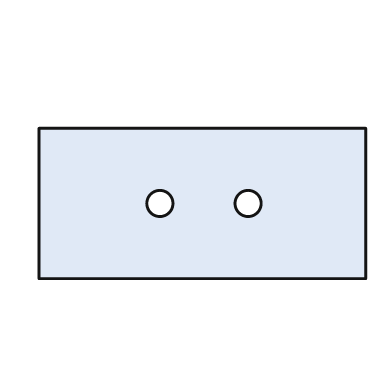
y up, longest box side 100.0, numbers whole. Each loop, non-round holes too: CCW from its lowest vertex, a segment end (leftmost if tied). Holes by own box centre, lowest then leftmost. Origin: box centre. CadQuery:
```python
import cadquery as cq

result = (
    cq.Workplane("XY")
    .moveTo(-50.0, -23.0)
    .lineTo(50.0, -23.0)
    .lineTo(50.0, 23.0)
    .lineTo(-50.0, 23.0)
    .close()
    .moveTo(-13.0, 0.0)
    .circle(4.0)
    .moveTo(14.0, 0.0)
    .circle(4.0)
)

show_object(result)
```